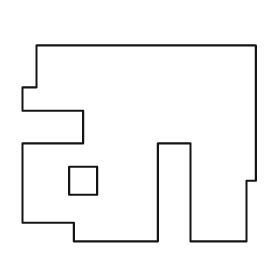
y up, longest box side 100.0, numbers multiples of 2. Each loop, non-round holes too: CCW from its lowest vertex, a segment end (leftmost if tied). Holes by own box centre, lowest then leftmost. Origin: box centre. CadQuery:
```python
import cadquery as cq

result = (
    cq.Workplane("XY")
    .moveTo(-28.0, -42.0)
    .lineTo(8.0, -42.0)
    .lineTo(8.0, 0.0)
    .lineTo(22.0, 0.0)
    .lineTo(22.0, -42.0)
    .lineTo(46.0, -42.0)
    .lineTo(46.0, -16.0)
    .lineTo(50.0, -16.0)
    .lineTo(50.0, 42.0)
    .lineTo(-44.0, 42.0)
    .lineTo(-44.0, 24.0)
    .lineTo(-50.0, 24.0)
    .lineTo(-50.0, 14.0)
    .lineTo(-24.0, 14.0)
    .lineTo(-24.0, 0.0)
    .lineTo(-50.0, 0.0)
    .lineTo(-50.0, -34.0)
    .lineTo(-28.0, -34.0)
    .close()
    .moveTo(-30.0, -22.0)
    .lineTo(-18.0, -22.0)
    .lineTo(-18.0, -10.0)
    .lineTo(-30.0, -10.0)
    .close()
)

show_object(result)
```